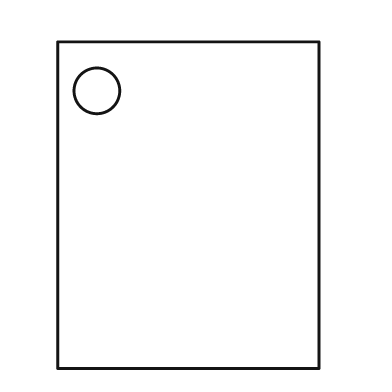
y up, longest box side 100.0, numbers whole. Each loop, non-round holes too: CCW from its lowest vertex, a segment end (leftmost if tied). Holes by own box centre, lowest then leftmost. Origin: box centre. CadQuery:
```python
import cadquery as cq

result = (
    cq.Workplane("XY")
    .moveTo(-40.0, -50.0)
    .lineTo(40.0, -50.0)
    .lineTo(40.0, 50.0)
    .lineTo(-40.0, 50.0)
    .close()
    .moveTo(-28.0, 35.0)
    .circle(7.0)
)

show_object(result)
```